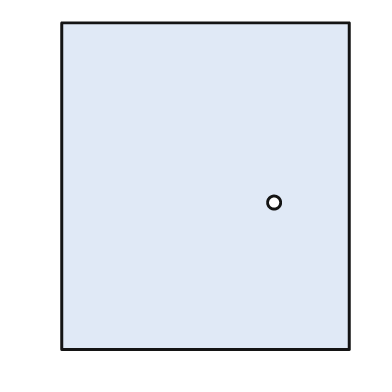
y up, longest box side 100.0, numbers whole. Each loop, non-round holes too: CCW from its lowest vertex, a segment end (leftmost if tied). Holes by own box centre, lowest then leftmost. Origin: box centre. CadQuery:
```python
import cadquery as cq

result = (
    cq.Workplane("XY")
    .moveTo(-44.0, -50.0)
    .lineTo(44.0, -50.0)
    .lineTo(44.0, 50.0)
    .lineTo(-44.0, 50.0)
    .close()
    .moveTo(21.0, -5.0)
    .circle(2.0)
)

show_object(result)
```